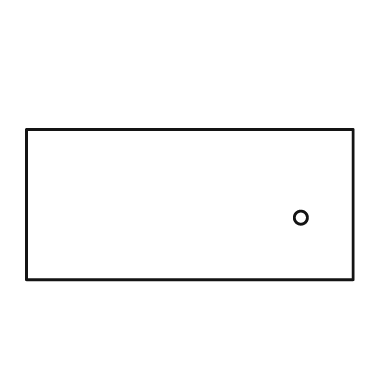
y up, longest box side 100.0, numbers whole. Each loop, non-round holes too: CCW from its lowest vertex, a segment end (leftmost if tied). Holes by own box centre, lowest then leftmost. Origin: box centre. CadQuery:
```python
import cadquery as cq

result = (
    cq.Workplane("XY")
    .moveTo(-50.0, -23.0)
    .lineTo(50.0, -23.0)
    .lineTo(50.0, 23.0)
    .lineTo(-50.0, 23.0)
    .close()
    .moveTo(34.0, -4.0)
    .circle(2.0)
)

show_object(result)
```